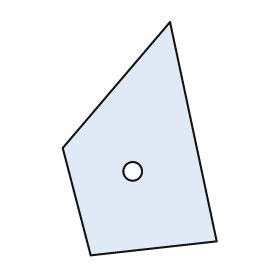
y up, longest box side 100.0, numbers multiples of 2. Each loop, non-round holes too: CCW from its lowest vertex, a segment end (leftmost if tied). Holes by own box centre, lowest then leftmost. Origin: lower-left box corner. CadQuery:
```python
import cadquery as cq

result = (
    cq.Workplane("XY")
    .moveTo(12.0, 0.0)
    .lineTo(66.0, 6.0)
    .lineTo(46.0, 100.0)
    .lineTo(0.0, 46.0)
    .close()
    .moveTo(30.0, 36.0)
    .circle(4.0)
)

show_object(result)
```